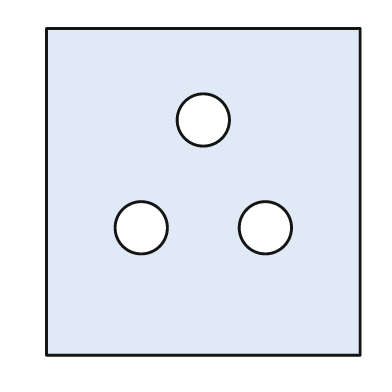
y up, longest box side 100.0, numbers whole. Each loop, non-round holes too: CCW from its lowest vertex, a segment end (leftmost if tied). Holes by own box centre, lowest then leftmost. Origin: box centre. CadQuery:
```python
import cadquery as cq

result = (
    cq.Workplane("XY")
    .moveTo(-48.0, -50.0)
    .lineTo(48.0, -50.0)
    .lineTo(48.0, 50.0)
    .lineTo(-48.0, 50.0)
    .close()
    .moveTo(-19.0, -11.0)
    .circle(8.0)
    .moveTo(19.0, -11.0)
    .circle(8.0)
    .moveTo(0.0, 22.0)
    .circle(8.0)
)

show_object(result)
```